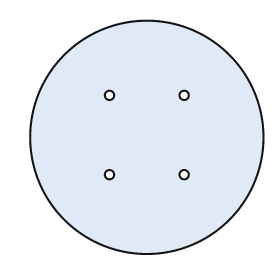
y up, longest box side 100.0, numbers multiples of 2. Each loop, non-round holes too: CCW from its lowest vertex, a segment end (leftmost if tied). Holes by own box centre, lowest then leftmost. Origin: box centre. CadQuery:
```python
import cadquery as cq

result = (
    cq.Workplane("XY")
    .moveTo(0.0, 0.0)
    .circle(50.0)
    .moveTo(-16.0, -16.0)
    .circle(2.0)
    .moveTo(16.0, -16.0)
    .circle(2.0)
    .moveTo(-16.0, 18.0)
    .circle(2.0)
    .moveTo(16.0, 18.0)
    .circle(2.0)
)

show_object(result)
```